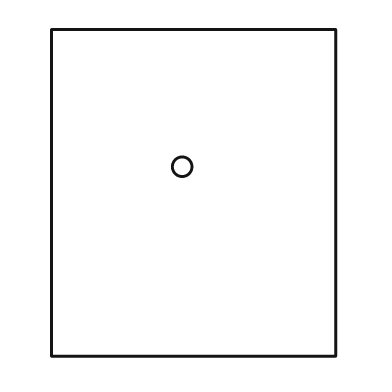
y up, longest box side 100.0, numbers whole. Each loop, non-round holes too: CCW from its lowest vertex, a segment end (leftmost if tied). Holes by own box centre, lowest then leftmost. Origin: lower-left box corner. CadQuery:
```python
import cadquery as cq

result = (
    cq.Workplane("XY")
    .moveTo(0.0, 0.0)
    .lineTo(87.0, 0.0)
    .lineTo(87.0, 100.0)
    .lineTo(0.0, 100.0)
    .close()
    .moveTo(40.0, 58.0)
    .circle(3.0)
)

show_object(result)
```